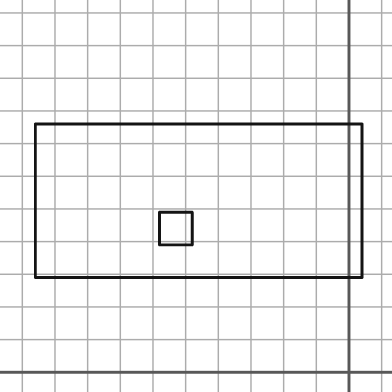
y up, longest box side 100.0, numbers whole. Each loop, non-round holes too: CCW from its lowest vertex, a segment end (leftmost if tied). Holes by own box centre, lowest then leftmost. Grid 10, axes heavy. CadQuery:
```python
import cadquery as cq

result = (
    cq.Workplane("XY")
    .moveTo(-96.0, 29.0)
    .lineTo(4.0, 29.0)
    .lineTo(4.0, 76.0)
    .lineTo(-96.0, 76.0)
    .close()
    .moveTo(-58.0, 39.0)
    .lineTo(-48.0, 39.0)
    .lineTo(-48.0, 49.0)
    .lineTo(-58.0, 49.0)
    .close()
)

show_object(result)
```